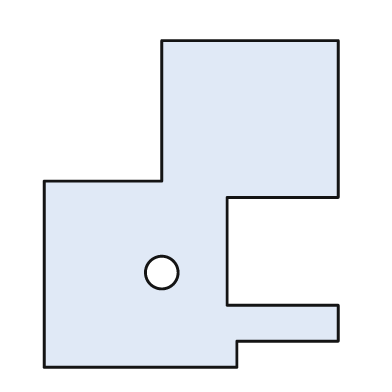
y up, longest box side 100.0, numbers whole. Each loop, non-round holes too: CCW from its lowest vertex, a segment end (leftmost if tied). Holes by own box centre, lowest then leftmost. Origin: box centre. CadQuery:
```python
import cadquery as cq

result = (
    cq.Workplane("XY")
    .moveTo(-45.0, -50.0)
    .lineTo(14.0, -50.0)
    .lineTo(14.0, -42.0)
    .lineTo(45.0, -42.0)
    .lineTo(45.0, -31.0)
    .lineTo(11.0, -31.0)
    .lineTo(11.0, 2.0)
    .lineTo(45.0, 2.0)
    .lineTo(45.0, 50.0)
    .lineTo(-9.0, 50.0)
    .lineTo(-9.0, 7.0)
    .lineTo(-45.0, 7.0)
    .close()
    .moveTo(-9.0, -21.0)
    .circle(5.0)
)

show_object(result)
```